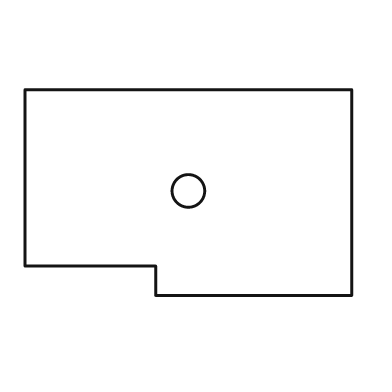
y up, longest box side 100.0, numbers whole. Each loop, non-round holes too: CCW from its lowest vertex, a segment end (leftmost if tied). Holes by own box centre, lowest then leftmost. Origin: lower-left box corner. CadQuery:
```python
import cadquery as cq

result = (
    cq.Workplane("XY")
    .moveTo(40.0, 0.0)
    .lineTo(100.0, 0.0)
    .lineTo(100.0, 63.0)
    .lineTo(0.0, 63.0)
    .lineTo(0.0, 9.0)
    .lineTo(40.0, 9.0)
    .close()
    .moveTo(50.0, 32.0)
    .circle(5.0)
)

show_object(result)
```